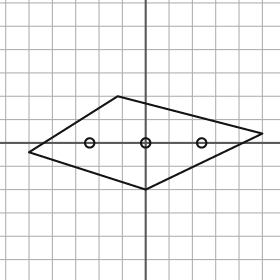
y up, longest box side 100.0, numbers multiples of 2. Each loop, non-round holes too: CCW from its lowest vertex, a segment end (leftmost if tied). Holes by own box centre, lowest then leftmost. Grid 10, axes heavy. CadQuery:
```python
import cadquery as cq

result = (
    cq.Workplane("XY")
    .moveTo(0.0, -20.0)
    .lineTo(50.0, 4.0)
    .lineTo(-12.0, 20.0)
    .lineTo(-50.0, -4.0)
    .close()
    .moveTo(-24.0, 0.0)
    .circle(2.0)
    .moveTo(0.0, 0.0)
    .circle(2.0)
    .moveTo(24.0, 0.0)
    .circle(2.0)
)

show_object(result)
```